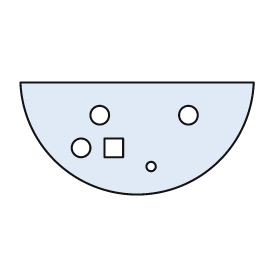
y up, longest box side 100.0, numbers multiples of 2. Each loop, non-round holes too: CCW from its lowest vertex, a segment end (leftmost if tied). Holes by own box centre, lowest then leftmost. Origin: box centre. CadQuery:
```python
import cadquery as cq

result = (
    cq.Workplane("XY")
    .moveTo(-50.0, 24.0)
    .threePointArc((0.0, -24.0), (50.0, 24.0))
    .close()
    .moveTo(6.0, -12.0)
    .circle(2.0)
    .moveTo(-24.0, -4.0)
    .circle(4.0)
    .moveTo(-14.0, -8.0)
    .lineTo(-6.0, -8.0)
    .lineTo(-6.0, 0.0)
    .lineTo(-14.0, 0.0)
    .close()
    .moveTo(-16.0, 10.0)
    .circle(4.0)
    .moveTo(22.0, 10.0)
    .circle(4.0)
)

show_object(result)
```